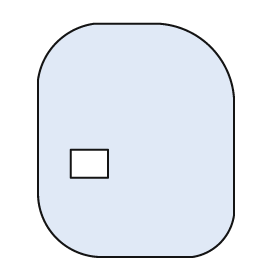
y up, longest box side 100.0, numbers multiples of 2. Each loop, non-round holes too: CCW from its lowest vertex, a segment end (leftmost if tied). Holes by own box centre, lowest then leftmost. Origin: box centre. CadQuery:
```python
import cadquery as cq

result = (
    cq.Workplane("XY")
    .moveTo(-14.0, -50.0)
    .lineTo(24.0, -50.0)
    .threePointArc((36.0, -44.0), (42.0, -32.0))
    .lineTo(42.0, 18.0)
    .threePointArc((32.0, 40.0), (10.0, 50.0))
    .lineTo(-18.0, 50.0)
    .threePointArc((-34.0, 42.0), (-42.0, 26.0))
    .lineTo(-42.0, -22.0)
    .threePointArc((-34.0, -42.0), (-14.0, -50.0))
    .close()
    .moveTo(-28.0, -16.0)
    .lineTo(-12.0, -16.0)
    .lineTo(-12.0, -4.0)
    .lineTo(-28.0, -4.0)
    .close()
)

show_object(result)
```